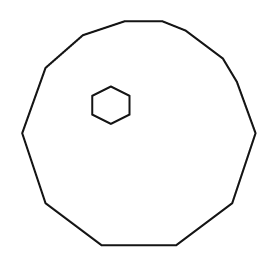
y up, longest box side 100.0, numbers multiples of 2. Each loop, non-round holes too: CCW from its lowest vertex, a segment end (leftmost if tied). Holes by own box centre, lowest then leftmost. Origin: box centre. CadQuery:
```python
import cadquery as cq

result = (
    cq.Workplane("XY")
    .moveTo(-16.0, -48.0)
    .lineTo(16.0, -48.0)
    .lineTo(40.0, -30.0)
    .lineTo(50.0, 0.0)
    .lineTo(42.0, 22.0)
    .lineTo(36.0, 32.0)
    .lineTo(20.0, 44.0)
    .lineTo(10.0, 48.0)
    .lineTo(-6.0, 48.0)
    .lineTo(-24.0, 42.0)
    .lineTo(-40.0, 28.0)
    .lineTo(-50.0, 0.0)
    .lineTo(-40.0, -30.0)
    .close()
    .moveTo(-12.0, 4.0)
    .lineTo(-4.0, 8.0)
    .lineTo(-4.0, 16.0)
    .lineTo(-12.0, 20.0)
    .lineTo(-20.0, 16.0)
    .lineTo(-20.0, 8.0)
    .close()
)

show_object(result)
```